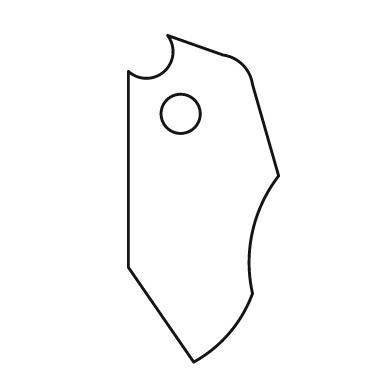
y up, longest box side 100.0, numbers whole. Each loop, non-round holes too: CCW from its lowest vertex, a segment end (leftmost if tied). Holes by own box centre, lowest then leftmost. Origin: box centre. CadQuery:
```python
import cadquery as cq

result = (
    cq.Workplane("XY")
    .moveTo(-3.0, -50.0)
    .threePointArc((8.0, -41.0), (15.0, -29.0))
    .threePointArc((15.0, -10.0), (23.0, 7.0))
    .lineTo(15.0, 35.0)
    .threePointArc((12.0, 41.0), (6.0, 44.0))
    .lineTo(-11.0, 50.0)
    .threePointArc((-12.0, 39.0), (-23.0, 39.0))
    .lineTo(-23.0, -21.0)
    .close()
    .moveTo(-7.0, 26.0)
    .circle(6.0)
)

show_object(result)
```